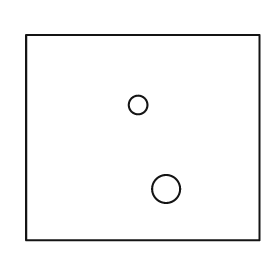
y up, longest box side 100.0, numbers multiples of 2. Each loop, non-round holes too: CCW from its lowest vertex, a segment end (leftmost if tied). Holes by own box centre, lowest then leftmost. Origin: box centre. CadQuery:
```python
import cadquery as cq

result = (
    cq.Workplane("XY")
    .moveTo(-50.0, -44.0)
    .lineTo(50.0, -44.0)
    .lineTo(50.0, 44.0)
    .lineTo(-50.0, 44.0)
    .close()
    .moveTo(10.0, -22.0)
    .circle(6.0)
    .moveTo(-2.0, 14.0)
    .circle(4.0)
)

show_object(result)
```